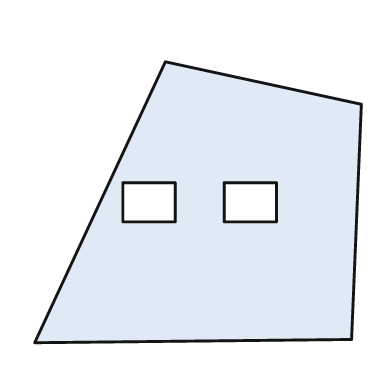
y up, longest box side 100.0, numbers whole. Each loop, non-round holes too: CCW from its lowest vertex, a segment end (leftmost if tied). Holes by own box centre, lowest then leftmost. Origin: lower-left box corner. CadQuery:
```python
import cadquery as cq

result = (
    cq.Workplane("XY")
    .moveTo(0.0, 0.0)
    .lineTo(97.0, 1.0)
    .lineTo(100.0, 73.0)
    .lineTo(40.0, 86.0)
    .close()
    .moveTo(27.0, 37.0)
    .lineTo(43.0, 37.0)
    .lineTo(43.0, 49.0)
    .lineTo(27.0, 49.0)
    .close()
    .moveTo(58.0, 37.0)
    .lineTo(74.0, 37.0)
    .lineTo(74.0, 49.0)
    .lineTo(58.0, 49.0)
    .close()
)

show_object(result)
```